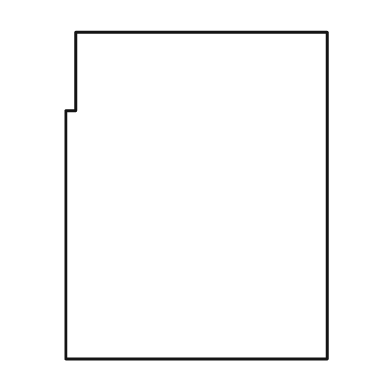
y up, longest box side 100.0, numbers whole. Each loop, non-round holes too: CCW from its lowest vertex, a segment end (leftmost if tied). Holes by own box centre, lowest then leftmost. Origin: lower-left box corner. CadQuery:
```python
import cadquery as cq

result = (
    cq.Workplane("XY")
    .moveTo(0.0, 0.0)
    .lineTo(80.0, 0.0)
    .lineTo(80.0, 100.0)
    .lineTo(3.0, 100.0)
    .lineTo(3.0, 76.0)
    .lineTo(0.0, 76.0)
    .close()
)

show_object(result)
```